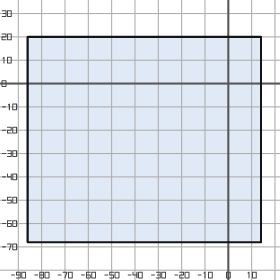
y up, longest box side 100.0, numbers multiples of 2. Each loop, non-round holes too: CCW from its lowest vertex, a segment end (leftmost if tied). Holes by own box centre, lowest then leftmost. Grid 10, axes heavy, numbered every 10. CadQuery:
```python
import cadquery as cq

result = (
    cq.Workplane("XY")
    .moveTo(-86.0, -68.0)
    .lineTo(14.0, -68.0)
    .lineTo(14.0, 20.0)
    .lineTo(-86.0, 20.0)
    .close()
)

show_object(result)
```